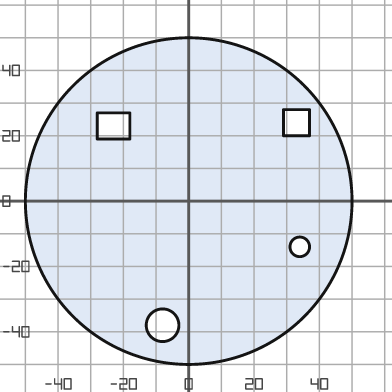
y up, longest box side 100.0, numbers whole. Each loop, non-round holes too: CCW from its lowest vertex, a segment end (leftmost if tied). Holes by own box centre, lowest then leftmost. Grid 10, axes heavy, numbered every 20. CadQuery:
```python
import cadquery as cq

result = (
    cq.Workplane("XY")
    .moveTo(0.0, 0.0)
    .circle(50.0)
    .moveTo(-8.0, -38.0)
    .circle(5.0)
    .moveTo(34.0, -14.0)
    .circle(3.0)
    .moveTo(-28.0, 19.0)
    .lineTo(-18.0, 19.0)
    .lineTo(-18.0, 27.0)
    .lineTo(-28.0, 27.0)
    .close()
    .moveTo(29.0, 20.0)
    .lineTo(37.0, 20.0)
    .lineTo(37.0, 28.0)
    .lineTo(29.0, 28.0)
    .close()
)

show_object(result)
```